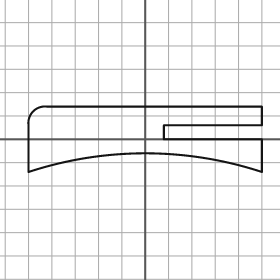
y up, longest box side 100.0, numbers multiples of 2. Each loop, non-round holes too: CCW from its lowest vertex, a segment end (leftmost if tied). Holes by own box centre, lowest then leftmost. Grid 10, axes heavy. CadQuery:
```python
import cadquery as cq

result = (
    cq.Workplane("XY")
    .moveTo(-50.0, -14.0)
    .threePointArc((0.0, -6.0), (50.0, -14.0))
    .lineTo(50.0, 0.0)
    .lineTo(8.0, 0.0)
    .lineTo(8.0, 6.0)
    .lineTo(50.0, 6.0)
    .lineTo(50.0, 14.0)
    .lineTo(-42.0, 14.0)
    .threePointArc((-48.0, 12.0), (-50.0, 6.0))
    .close()
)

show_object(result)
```